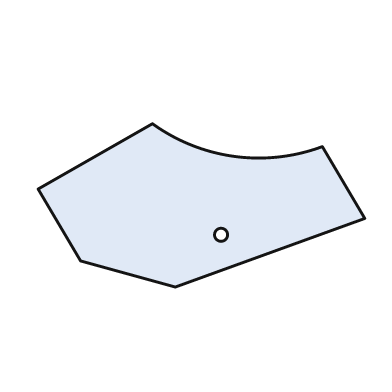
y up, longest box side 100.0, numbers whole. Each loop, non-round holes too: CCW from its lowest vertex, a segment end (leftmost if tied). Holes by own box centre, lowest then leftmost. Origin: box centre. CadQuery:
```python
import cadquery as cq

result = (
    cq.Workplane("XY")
    .moveTo(-8.0, -25.0)
    .lineTo(50.0, -4.0)
    .lineTo(37.0, 18.0)
    .threePointArc((10.0, 15.0), (-15.0, 25.0))
    .lineTo(-50.0, 5.0)
    .lineTo(-37.0, -17.0)
    .close()
    .moveTo(6.0, -9.0)
    .circle(2.0)
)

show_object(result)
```